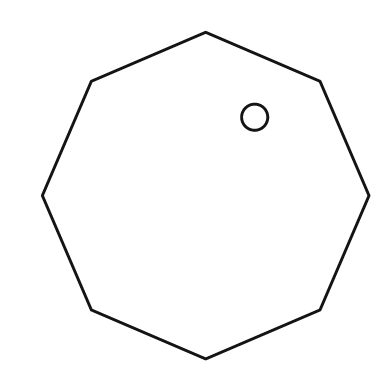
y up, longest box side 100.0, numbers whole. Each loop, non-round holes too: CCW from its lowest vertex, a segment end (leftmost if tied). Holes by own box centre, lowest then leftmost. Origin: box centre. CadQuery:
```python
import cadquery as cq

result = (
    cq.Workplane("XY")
    .moveTo(0.0, -50.0)
    .lineTo(35.0, -35.0)
    .lineTo(50.0, 0.0)
    .lineTo(35.0, 35.0)
    .lineTo(0.0, 50.0)
    .lineTo(-35.0, 35.0)
    .lineTo(-50.0, 0.0)
    .lineTo(-35.0, -35.0)
    .close()
    .moveTo(15.0, 24.0)
    .circle(4.0)
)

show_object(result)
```